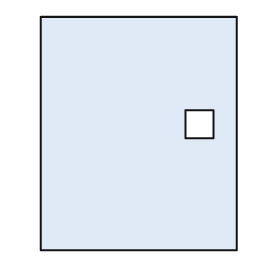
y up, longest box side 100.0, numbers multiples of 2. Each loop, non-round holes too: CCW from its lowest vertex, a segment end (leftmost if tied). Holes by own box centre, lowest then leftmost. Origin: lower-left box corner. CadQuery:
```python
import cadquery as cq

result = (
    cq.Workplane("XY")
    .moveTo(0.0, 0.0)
    .lineTo(84.0, 0.0)
    .lineTo(84.0, 100.0)
    .lineTo(0.0, 100.0)
    .close()
    .moveTo(62.0, 48.0)
    .lineTo(74.0, 48.0)
    .lineTo(74.0, 60.0)
    .lineTo(62.0, 60.0)
    .close()
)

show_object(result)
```